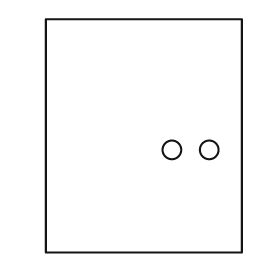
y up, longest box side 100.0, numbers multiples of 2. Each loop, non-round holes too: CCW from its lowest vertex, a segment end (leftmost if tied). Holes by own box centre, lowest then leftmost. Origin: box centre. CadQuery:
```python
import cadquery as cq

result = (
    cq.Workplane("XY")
    .moveTo(-42.0, -50.0)
    .lineTo(42.0, -50.0)
    .lineTo(42.0, 50.0)
    .lineTo(-42.0, 50.0)
    .close()
    .moveTo(12.0, -6.0)
    .circle(4.0)
    .moveTo(28.0, -6.0)
    .circle(4.0)
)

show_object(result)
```